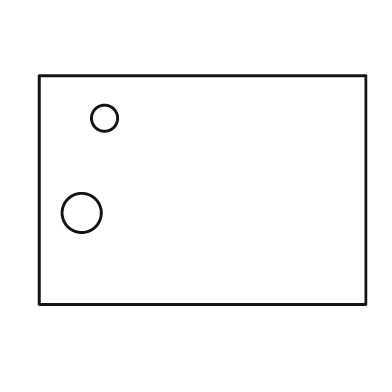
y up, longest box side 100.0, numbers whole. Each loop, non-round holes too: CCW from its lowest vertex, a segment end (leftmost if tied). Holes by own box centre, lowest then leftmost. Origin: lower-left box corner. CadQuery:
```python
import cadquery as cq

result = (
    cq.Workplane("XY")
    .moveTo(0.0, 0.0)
    .lineTo(100.0, 0.0)
    .lineTo(100.0, 70.0)
    .lineTo(0.0, 70.0)
    .close()
    .moveTo(13.0, 28.0)
    .circle(6.0)
    .moveTo(20.0, 57.0)
    .circle(4.0)
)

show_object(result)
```